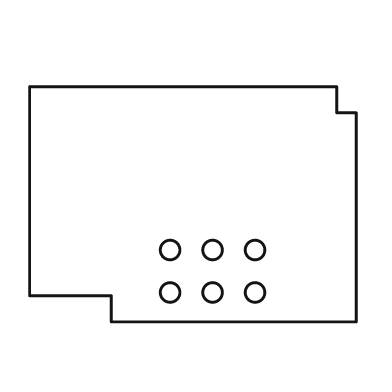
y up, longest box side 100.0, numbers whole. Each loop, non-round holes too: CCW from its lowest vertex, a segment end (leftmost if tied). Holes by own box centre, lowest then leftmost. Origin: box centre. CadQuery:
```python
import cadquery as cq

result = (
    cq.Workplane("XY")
    .moveTo(-25.0, -36.0)
    .lineTo(50.0, -36.0)
    .lineTo(50.0, 28.0)
    .lineTo(44.0, 28.0)
    .lineTo(44.0, 36.0)
    .lineTo(-50.0, 36.0)
    .lineTo(-50.0, -28.0)
    .lineTo(-25.0, -28.0)
    .close()
    .moveTo(-7.0, -27.0)
    .circle(3.0)
    .moveTo(6.0, -27.0)
    .circle(3.0)
    .moveTo(19.0, -27.0)
    .circle(3.0)
    .moveTo(-7.0, -14.0)
    .circle(3.0)
    .moveTo(6.0, -14.0)
    .circle(3.0)
    .moveTo(19.0, -14.0)
    .circle(3.0)
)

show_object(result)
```